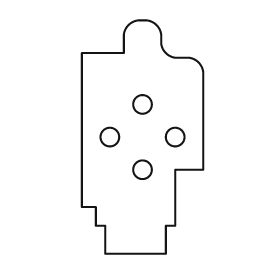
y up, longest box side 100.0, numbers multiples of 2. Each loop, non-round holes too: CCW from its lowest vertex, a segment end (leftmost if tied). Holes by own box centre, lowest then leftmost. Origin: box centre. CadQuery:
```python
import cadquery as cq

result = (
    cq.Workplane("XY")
    .moveTo(-16.0, -50.0)
    .lineTo(10.0, -50.0)
    .lineTo(10.0, -38.0)
    .lineTo(14.0, -38.0)
    .lineTo(14.0, -14.0)
    .lineTo(26.0, -14.0)
    .lineTo(26.0, 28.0)
    .threePointArc((24.0, 32.0), (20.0, 34.0))
    .lineTo(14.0, 34.0)
    .threePointArc((10.0, 36.0), (8.0, 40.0))
    .lineTo(8.0, 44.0)
    .threePointArc((6.0, 48.0), (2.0, 50.0))
    .lineTo(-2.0, 50.0)
    .threePointArc((-6.0, 48.0), (-8.0, 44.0))
    .lineTo(-8.0, 36.0)
    .lineTo(-26.0, 36.0)
    .lineTo(-26.0, -30.0)
    .lineTo(-20.0, -30.0)
    .lineTo(-20.0, -38.0)
    .lineTo(-16.0, -38.0)
    .close()
    .moveTo(0.0, -14.0)
    .circle(4.0)
    .moveTo(-14.0, 0.0)
    .circle(4.0)
    .moveTo(14.0, 0.0)
    .circle(4.0)
    .moveTo(0.0, 14.0)
    .circle(4.0)
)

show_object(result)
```